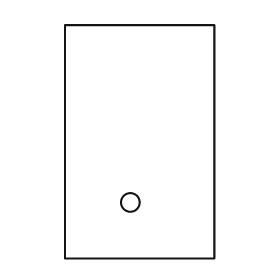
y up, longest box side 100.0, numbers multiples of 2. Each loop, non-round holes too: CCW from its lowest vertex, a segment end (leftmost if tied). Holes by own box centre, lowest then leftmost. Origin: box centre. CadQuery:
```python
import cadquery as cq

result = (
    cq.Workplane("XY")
    .moveTo(-32.0, -50.0)
    .lineTo(32.0, -50.0)
    .lineTo(32.0, 50.0)
    .lineTo(-32.0, 50.0)
    .close()
    .moveTo(-4.0, -26.0)
    .circle(4.0)
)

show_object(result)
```